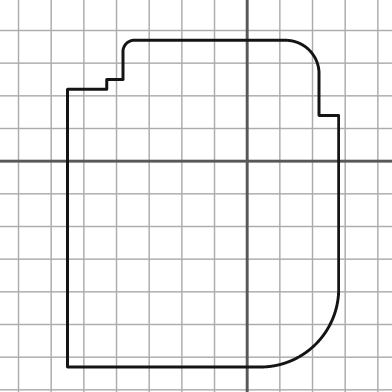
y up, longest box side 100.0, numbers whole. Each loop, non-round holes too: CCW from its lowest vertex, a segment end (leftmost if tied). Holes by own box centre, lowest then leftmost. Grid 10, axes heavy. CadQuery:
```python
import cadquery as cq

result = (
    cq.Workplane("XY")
    .moveTo(-55.0, -63.0)
    .lineTo(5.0, -63.0)
    .threePointArc((21.0, -56.0), (28.0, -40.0))
    .lineTo(28.0, 14.0)
    .lineTo(22.0, 14.0)
    .lineTo(22.0, 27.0)
    .threePointArc((19.0, 34.0), (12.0, 37.0))
    .lineTo(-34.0, 37.0)
    .threePointArc((-37.0, 36.0), (-38.0, 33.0))
    .lineTo(-38.0, 25.0)
    .lineTo(-43.0, 25.0)
    .lineTo(-43.0, 22.0)
    .lineTo(-55.0, 22.0)
    .close()
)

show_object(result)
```